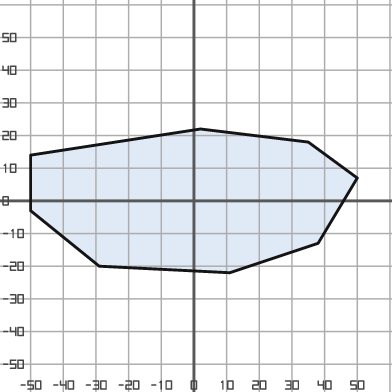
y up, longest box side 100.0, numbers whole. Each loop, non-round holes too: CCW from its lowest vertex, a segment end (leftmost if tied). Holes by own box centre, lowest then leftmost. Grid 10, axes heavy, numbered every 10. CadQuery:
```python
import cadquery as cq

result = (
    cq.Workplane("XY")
    .moveTo(11.0, -22.0)
    .lineTo(38.0, -13.0)
    .lineTo(50.0, 7.0)
    .lineTo(35.0, 18.0)
    .lineTo(2.0, 22.0)
    .lineTo(-50.0, 14.0)
    .lineTo(-50.0, -3.0)
    .lineTo(-29.0, -20.0)
    .close()
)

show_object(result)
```